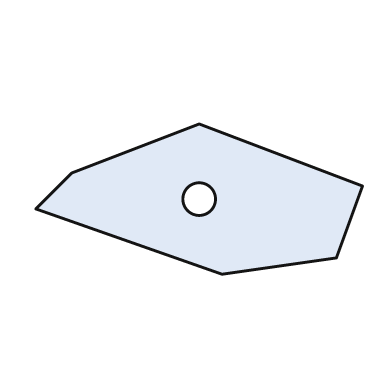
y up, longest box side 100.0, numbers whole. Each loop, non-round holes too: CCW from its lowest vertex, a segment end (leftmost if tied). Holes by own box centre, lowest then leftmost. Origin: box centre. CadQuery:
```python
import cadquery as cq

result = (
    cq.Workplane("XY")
    .moveTo(7.0, -23.0)
    .lineTo(42.0, -18.0)
    .lineTo(50.0, 4.0)
    .lineTo(0.0, 23.0)
    .lineTo(-39.0, 8.0)
    .lineTo(-50.0, -3.0)
    .close()
    .moveTo(0.0, 0.0)
    .circle(5.0)
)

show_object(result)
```